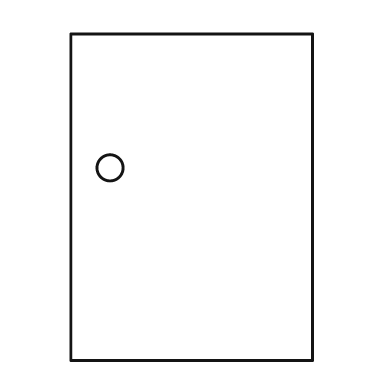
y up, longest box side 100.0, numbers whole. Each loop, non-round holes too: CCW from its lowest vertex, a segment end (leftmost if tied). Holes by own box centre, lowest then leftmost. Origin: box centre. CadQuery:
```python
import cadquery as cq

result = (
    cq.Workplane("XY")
    .moveTo(-37.0, -50.0)
    .lineTo(37.0, -50.0)
    .lineTo(37.0, 50.0)
    .lineTo(-37.0, 50.0)
    .close()
    .moveTo(-25.0, 9.0)
    .circle(4.0)
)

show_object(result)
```